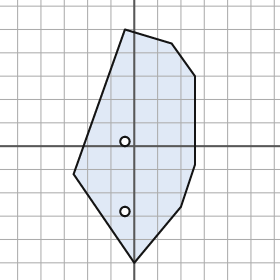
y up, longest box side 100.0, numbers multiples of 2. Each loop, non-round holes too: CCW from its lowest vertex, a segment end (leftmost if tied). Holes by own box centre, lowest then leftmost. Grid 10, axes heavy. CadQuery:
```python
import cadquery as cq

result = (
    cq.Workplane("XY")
    .moveTo(0.0, -50.0)
    .lineTo(20.0, -26.0)
    .lineTo(26.0, -8.0)
    .lineTo(26.0, 30.0)
    .lineTo(16.0, 44.0)
    .lineTo(-4.0, 50.0)
    .lineTo(-26.0, -12.0)
    .close()
    .moveTo(-4.0, -28.0)
    .circle(2.0)
    .moveTo(-4.0, 2.0)
    .circle(2.0)
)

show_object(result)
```